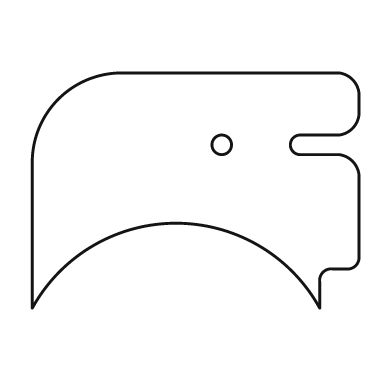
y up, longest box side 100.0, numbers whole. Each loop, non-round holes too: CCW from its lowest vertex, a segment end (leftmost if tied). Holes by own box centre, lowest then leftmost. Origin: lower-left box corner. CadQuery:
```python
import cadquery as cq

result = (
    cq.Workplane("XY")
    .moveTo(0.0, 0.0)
    .threePointArc((44.0, 26.0), (88.0, 0.0))
    .lineTo(88.0, 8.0)
    .threePointArc((89.0, 11.0), (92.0, 12.0))
    .lineTo(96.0, 12.0)
    .threePointArc((99.0, 13.0), (100.0, 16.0))
    .lineTo(100.0, 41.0)
    .threePointArc((98.0, 45.0), (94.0, 47.0))
    .lineTo(82.0, 47.0)
    .threePointArc((79.0, 50.0), (82.0, 53.0))
    .lineTo(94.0, 53.0)
    .threePointArc((98.0, 55.0), (100.0, 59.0))
    .lineTo(100.0, 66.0)
    .threePointArc((98.0, 70.0), (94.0, 72.0))
    .lineTo(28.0, 72.0)
    .threePointArc((8.0, 64.0), (0.0, 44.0))
    .close()
    .moveTo(58.0, 50.0)
    .circle(3.0)
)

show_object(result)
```